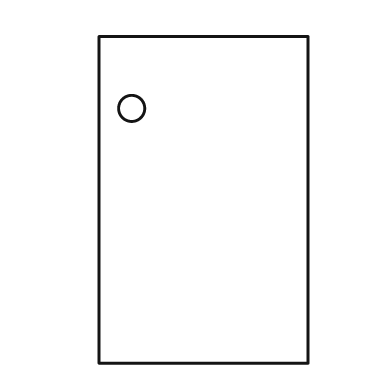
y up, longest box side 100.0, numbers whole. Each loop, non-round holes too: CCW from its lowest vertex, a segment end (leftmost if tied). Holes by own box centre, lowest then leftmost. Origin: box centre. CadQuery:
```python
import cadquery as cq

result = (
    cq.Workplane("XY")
    .moveTo(-32.0, -50.0)
    .lineTo(32.0, -50.0)
    .lineTo(32.0, 50.0)
    .lineTo(-32.0, 50.0)
    .close()
    .moveTo(-22.0, 28.0)
    .circle(4.0)
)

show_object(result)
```